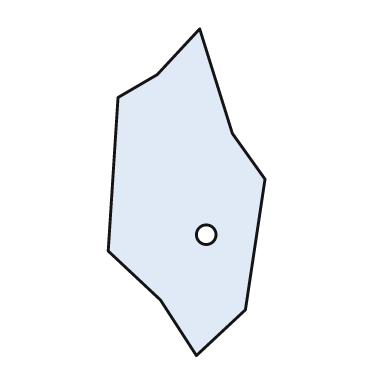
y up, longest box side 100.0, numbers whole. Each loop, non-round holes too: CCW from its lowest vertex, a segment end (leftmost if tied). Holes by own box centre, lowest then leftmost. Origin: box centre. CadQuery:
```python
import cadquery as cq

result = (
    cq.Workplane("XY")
    .moveTo(3.0, -50.0)
    .lineTo(18.0, -36.0)
    .lineTo(24.0, 4.0)
    .lineTo(14.0, 18.0)
    .lineTo(4.0, 50.0)
    .lineTo(-9.0, 36.0)
    .lineTo(-21.0, 29.0)
    .lineTo(-24.0, -18.0)
    .lineTo(-8.0, -33.0)
    .close()
    .moveTo(6.0, -13.0)
    .circle(3.0)
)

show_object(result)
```